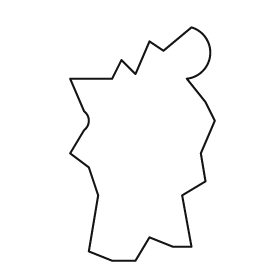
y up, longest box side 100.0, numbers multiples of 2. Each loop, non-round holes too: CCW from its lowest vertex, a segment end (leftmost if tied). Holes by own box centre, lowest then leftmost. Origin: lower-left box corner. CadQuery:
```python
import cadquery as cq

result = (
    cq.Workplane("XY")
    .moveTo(18.0, 0.0)
    .lineTo(28.0, 0.0)
    .lineTo(34.0, 10.0)
    .lineTo(44.0, 6.0)
    .lineTo(52.0, 6.0)
    .lineTo(48.0, 28.0)
    .lineTo(58.0, 34.0)
    .lineTo(56.0, 46.0)
    .lineTo(62.0, 60.0)
    .lineTo(58.0, 68.0)
    .lineTo(50.0, 78.0)
    .threePointArc((60.0, 88.0), (52.0, 100.0))
    .lineTo(40.0, 90.0)
    .lineTo(34.0, 94.0)
    .lineTo(28.0, 80.0)
    .lineTo(22.0, 86.0)
    .lineTo(18.0, 78.0)
    .lineTo(0.0, 78.0)
    .lineTo(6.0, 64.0)
    .threePointArc((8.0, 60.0), (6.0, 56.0))
    .lineTo(0.0, 46.0)
    .lineTo(8.0, 40.0)
    .lineTo(12.0, 28.0)
    .lineTo(8.0, 4.0)
    .close()
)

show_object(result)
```